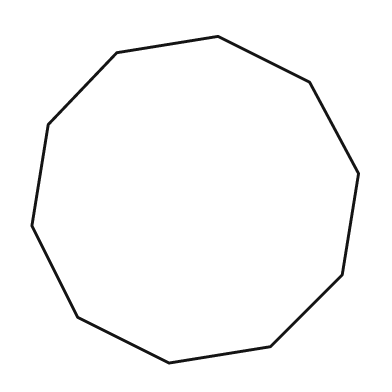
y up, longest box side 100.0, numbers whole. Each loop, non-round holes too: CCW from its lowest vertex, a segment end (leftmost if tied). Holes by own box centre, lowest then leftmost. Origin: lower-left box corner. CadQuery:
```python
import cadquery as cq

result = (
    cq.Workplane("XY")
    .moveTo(42.0, 0.0)
    .lineTo(73.0, 5.0)
    .lineTo(95.0, 27.0)
    .lineTo(100.0, 58.0)
    .lineTo(85.0, 86.0)
    .lineTo(57.0, 100.0)
    .lineTo(26.0, 95.0)
    .lineTo(5.0, 73.0)
    .lineTo(0.0, 42.0)
    .lineTo(14.0, 14.0)
    .close()
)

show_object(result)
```